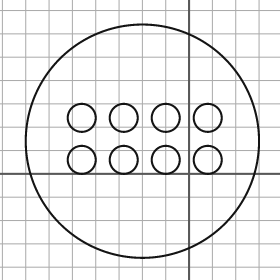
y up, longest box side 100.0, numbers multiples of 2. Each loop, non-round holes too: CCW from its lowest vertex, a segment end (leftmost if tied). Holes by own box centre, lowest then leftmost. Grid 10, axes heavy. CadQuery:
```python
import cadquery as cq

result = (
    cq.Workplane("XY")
    .moveTo(-20.0, 14.0)
    .circle(50.0)
    .moveTo(-46.0, 6.0)
    .circle(6.0)
    .moveTo(-28.0, 6.0)
    .circle(6.0)
    .moveTo(-10.0, 6.0)
    .circle(6.0)
    .moveTo(8.0, 6.0)
    .circle(6.0)
    .moveTo(-46.0, 24.0)
    .circle(6.0)
    .moveTo(-28.0, 24.0)
    .circle(6.0)
    .moveTo(-10.0, 24.0)
    .circle(6.0)
    .moveTo(8.0, 24.0)
    .circle(6.0)
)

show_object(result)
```